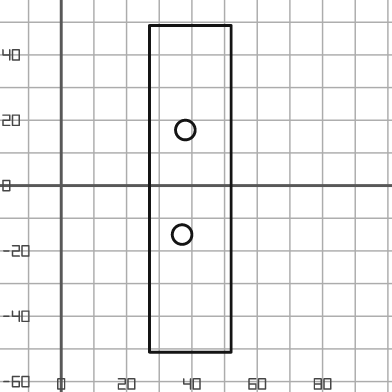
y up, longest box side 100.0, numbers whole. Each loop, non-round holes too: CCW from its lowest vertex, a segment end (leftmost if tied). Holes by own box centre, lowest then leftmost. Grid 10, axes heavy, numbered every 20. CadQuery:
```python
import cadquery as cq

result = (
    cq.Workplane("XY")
    .moveTo(27.0, -51.0)
    .lineTo(52.0, -51.0)
    .lineTo(52.0, 49.0)
    .lineTo(27.0, 49.0)
    .close()
    .moveTo(37.0, -15.0)
    .circle(3.0)
    .moveTo(38.0, 17.0)
    .circle(3.0)
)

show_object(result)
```